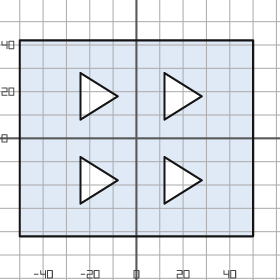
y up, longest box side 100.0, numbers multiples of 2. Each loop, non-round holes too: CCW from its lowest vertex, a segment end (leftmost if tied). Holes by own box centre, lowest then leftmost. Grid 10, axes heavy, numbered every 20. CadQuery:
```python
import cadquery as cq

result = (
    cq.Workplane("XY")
    .moveTo(-50.0, -42.0)
    .lineTo(50.0, -42.0)
    .lineTo(50.0, 42.0)
    .lineTo(-50.0, 42.0)
    .close()
    .moveTo(-24.0, -28.0)
    .lineTo(-8.0, -18.0)
    .lineTo(-24.0, -8.0)
    .close()
    .moveTo(12.0, -28.0)
    .lineTo(28.0, -18.0)
    .lineTo(12.0, -8.0)
    .close()
    .moveTo(-24.0, 8.0)
    .lineTo(-8.0, 18.0)
    .lineTo(-24.0, 28.0)
    .close()
    .moveTo(12.0, 8.0)
    .lineTo(28.0, 18.0)
    .lineTo(12.0, 28.0)
    .close()
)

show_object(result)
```